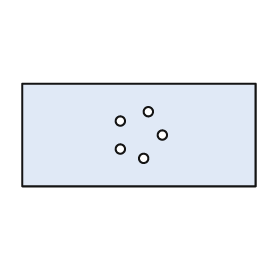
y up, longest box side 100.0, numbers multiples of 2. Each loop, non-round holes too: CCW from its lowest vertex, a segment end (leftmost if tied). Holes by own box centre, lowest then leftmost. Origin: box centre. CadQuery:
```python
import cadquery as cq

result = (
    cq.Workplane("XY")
    .moveTo(-50.0, -22.0)
    .lineTo(50.0, -22.0)
    .lineTo(50.0, 22.0)
    .lineTo(-50.0, 22.0)
    .close()
    .moveTo(2.0, -10.0)
    .circle(2.0)
    .moveTo(-8.0, -6.0)
    .circle(2.0)
    .moveTo(10.0, 0.0)
    .circle(2.0)
    .moveTo(-8.0, 6.0)
    .circle(2.0)
    .moveTo(4.0, 10.0)
    .circle(2.0)
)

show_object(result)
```